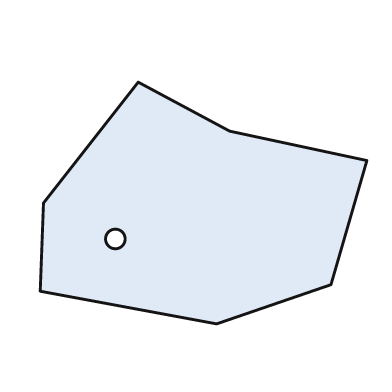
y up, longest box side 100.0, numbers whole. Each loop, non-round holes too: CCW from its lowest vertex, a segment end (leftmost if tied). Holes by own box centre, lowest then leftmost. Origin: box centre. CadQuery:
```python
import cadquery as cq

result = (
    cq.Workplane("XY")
    .moveTo(4.0, -37.0)
    .lineTo(39.0, -25.0)
    .lineTo(50.0, 13.0)
    .lineTo(8.0, 22.0)
    .lineTo(-20.0, 37.0)
    .lineTo(-49.0, 0.0)
    .lineTo(-50.0, -27.0)
    .close()
    .moveTo(-27.0, -11.0)
    .circle(3.0)
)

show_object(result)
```